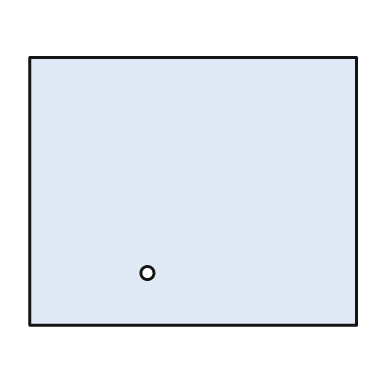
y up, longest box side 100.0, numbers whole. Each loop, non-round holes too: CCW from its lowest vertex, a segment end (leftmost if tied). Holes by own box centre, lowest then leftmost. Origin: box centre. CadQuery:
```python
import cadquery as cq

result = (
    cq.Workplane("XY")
    .moveTo(-50.0, -41.0)
    .lineTo(50.0, -41.0)
    .lineTo(50.0, 41.0)
    .lineTo(-50.0, 41.0)
    .close()
    .moveTo(-14.0, -25.0)
    .circle(2.0)
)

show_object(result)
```